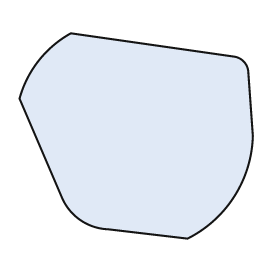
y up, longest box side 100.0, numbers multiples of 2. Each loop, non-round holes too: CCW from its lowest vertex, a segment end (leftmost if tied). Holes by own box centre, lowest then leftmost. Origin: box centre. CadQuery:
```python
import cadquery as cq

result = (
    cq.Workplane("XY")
    .moveTo(22.0, -44.0)
    .threePointArc((42.0, -26.0), (50.0, 0.0))
    .lineTo(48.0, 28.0)
    .threePointArc((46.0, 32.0), (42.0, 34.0))
    .lineTo(-28.0, 44.0)
    .threePointArc((-42.0, 32.0), (-50.0, 16.0))
    .lineTo(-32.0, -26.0)
    .threePointArc((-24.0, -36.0), (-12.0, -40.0))
    .close()
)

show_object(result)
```